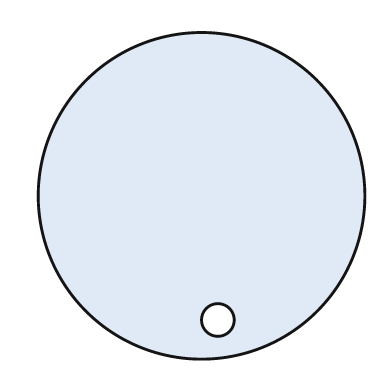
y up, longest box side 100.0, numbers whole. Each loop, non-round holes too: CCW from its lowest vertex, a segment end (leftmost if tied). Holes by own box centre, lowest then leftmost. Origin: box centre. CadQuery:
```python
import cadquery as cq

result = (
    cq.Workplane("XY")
    .moveTo(0.0, 0.0)
    .circle(50.0)
    .moveTo(5.0, -38.0)
    .circle(5.0)
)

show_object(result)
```